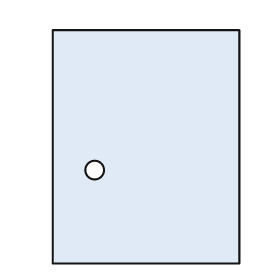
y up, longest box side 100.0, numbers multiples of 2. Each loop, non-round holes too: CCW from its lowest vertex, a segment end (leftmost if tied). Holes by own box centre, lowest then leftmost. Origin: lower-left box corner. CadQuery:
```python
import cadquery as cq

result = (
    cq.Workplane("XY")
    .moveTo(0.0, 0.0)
    .lineTo(80.0, 0.0)
    .lineTo(80.0, 100.0)
    .lineTo(0.0, 100.0)
    .close()
    .moveTo(18.0, 40.0)
    .circle(4.0)
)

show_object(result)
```